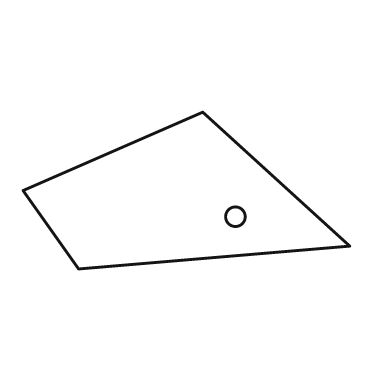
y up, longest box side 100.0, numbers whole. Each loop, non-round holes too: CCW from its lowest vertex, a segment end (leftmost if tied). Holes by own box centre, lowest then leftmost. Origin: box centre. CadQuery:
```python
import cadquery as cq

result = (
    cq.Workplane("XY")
    .moveTo(-33.0, -24.0)
    .lineTo(50.0, -17.0)
    .lineTo(5.0, 24.0)
    .lineTo(-50.0, 0.0)
    .close()
    .moveTo(15.0, -8.0)
    .circle(3.0)
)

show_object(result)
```